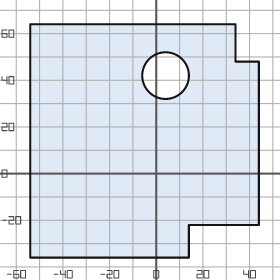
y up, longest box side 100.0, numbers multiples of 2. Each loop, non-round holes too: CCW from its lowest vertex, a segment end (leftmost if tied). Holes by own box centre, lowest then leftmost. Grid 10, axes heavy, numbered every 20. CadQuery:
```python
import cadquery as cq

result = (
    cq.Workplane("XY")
    .moveTo(-54.0, -36.0)
    .lineTo(14.0, -36.0)
    .lineTo(14.0, -22.0)
    .lineTo(44.0, -22.0)
    .lineTo(44.0, 48.0)
    .lineTo(34.0, 48.0)
    .lineTo(34.0, 64.0)
    .lineTo(-54.0, 64.0)
    .close()
    .moveTo(4.0, 42.0)
    .circle(10.0)
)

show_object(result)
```